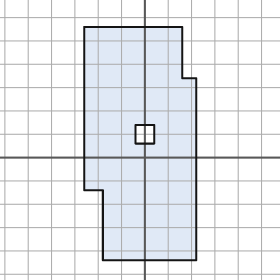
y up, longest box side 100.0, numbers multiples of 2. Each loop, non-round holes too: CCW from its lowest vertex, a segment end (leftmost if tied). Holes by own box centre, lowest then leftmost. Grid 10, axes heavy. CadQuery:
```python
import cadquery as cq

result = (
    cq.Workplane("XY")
    .moveTo(-18.0, -44.0)
    .lineTo(22.0, -44.0)
    .lineTo(22.0, 34.0)
    .lineTo(16.0, 34.0)
    .lineTo(16.0, 56.0)
    .lineTo(-26.0, 56.0)
    .lineTo(-26.0, -14.0)
    .lineTo(-18.0, -14.0)
    .close()
    .moveTo(-4.0, 6.0)
    .lineTo(4.0, 6.0)
    .lineTo(4.0, 14.0)
    .lineTo(-4.0, 14.0)
    .close()
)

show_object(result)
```